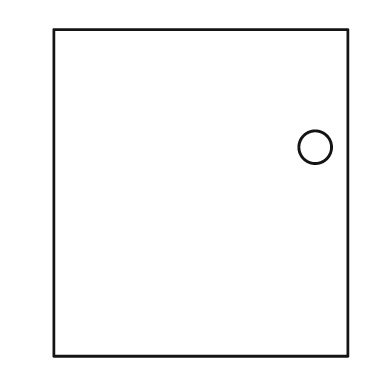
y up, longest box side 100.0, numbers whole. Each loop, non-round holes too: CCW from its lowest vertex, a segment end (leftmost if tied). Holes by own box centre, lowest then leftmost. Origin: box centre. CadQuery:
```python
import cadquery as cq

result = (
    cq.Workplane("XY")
    .moveTo(-45.0, -50.0)
    .lineTo(45.0, -50.0)
    .lineTo(45.0, 50.0)
    .lineTo(-45.0, 50.0)
    .close()
    .moveTo(35.0, 14.0)
    .circle(5.0)
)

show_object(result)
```